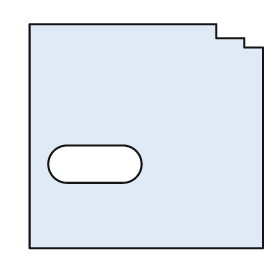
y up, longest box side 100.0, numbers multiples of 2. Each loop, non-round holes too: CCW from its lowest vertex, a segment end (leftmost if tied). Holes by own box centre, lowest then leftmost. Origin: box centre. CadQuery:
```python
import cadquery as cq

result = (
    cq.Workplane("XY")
    .moveTo(-50.0, -48.0)
    .lineTo(50.0, -48.0)
    .lineTo(50.0, 38.0)
    .lineTo(42.0, 38.0)
    .lineTo(42.0, 42.0)
    .lineTo(30.0, 42.0)
    .lineTo(30.0, 48.0)
    .lineTo(-50.0, 48.0)
    .close()
    .moveTo(-34.0, -20.0)
    .lineTo(-10.0, -20.0)
    .threePointArc((-2.0, -12.0), (-10.0, -4.0))
    .lineTo(-34.0, -4.0)
    .threePointArc((-42.0, -12.0), (-34.0, -20.0))
    .close()
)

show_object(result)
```